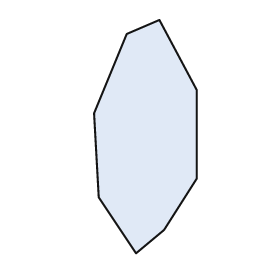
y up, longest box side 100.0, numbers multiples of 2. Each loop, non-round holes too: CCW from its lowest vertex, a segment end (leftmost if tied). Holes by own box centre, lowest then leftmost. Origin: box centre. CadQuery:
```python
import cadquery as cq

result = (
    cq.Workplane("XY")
    .moveTo(-4.0, -50.0)
    .lineTo(8.0, -40.0)
    .lineTo(22.0, -18.0)
    .lineTo(22.0, 20.0)
    .lineTo(6.0, 50.0)
    .lineTo(-8.0, 44.0)
    .lineTo(-22.0, 10.0)
    .lineTo(-20.0, -26.0)
    .close()
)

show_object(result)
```